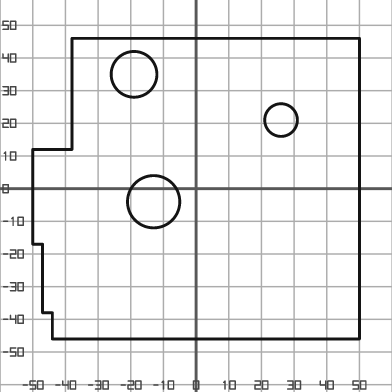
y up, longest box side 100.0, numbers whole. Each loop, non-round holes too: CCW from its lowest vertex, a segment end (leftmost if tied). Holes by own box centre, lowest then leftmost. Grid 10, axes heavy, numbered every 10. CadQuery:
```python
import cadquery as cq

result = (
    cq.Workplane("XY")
    .moveTo(-44.0, -46.0)
    .lineTo(50.0, -46.0)
    .lineTo(50.0, 46.0)
    .lineTo(-38.0, 46.0)
    .lineTo(-38.0, 12.0)
    .lineTo(-50.0, 12.0)
    .lineTo(-50.0, -17.0)
    .lineTo(-47.0, -17.0)
    .lineTo(-47.0, -38.0)
    .lineTo(-44.0, -38.0)
    .close()
    .moveTo(-13.0, -4.0)
    .circle(8.0)
    .moveTo(26.0, 21.0)
    .circle(5.0)
    .moveTo(-19.0, 35.0)
    .circle(7.0)
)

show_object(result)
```